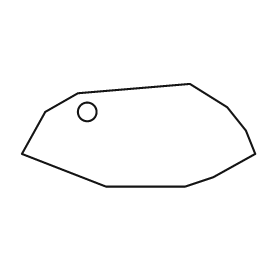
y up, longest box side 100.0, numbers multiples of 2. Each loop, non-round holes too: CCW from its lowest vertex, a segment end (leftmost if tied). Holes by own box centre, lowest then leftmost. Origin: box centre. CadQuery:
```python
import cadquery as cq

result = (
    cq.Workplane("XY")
    .moveTo(-14.0, -22.0)
    .lineTo(20.0, -22.0)
    .lineTo(32.0, -18.0)
    .lineTo(50.0, -8.0)
    .lineTo(46.0, 2.0)
    .lineTo(38.0, 12.0)
    .lineTo(22.0, 22.0)
    .lineTo(-26.0, 18.0)
    .lineTo(-40.0, 10.0)
    .lineTo(-50.0, -8.0)
    .close()
    .moveTo(-22.0, 10.0)
    .circle(4.0)
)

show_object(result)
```